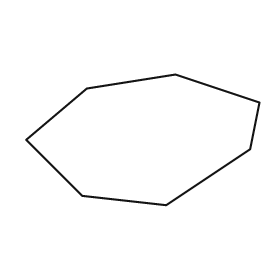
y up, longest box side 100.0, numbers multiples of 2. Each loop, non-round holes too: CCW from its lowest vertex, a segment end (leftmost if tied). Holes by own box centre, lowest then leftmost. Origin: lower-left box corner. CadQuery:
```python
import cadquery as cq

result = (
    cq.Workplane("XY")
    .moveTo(60.0, 0.0)
    .lineTo(96.0, 24.0)
    .lineTo(100.0, 44.0)
    .lineTo(64.0, 56.0)
    .lineTo(26.0, 50.0)
    .lineTo(0.0, 28.0)
    .lineTo(24.0, 4.0)
    .close()
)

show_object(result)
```